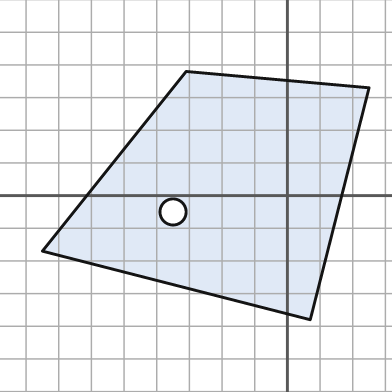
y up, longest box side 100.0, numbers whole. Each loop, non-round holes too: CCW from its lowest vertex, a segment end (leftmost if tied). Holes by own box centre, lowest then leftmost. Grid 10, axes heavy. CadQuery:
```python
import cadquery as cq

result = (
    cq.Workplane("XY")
    .moveTo(7.0, -38.0)
    .lineTo(25.0, 33.0)
    .lineTo(-31.0, 38.0)
    .lineTo(-75.0, -17.0)
    .close()
    .moveTo(-35.0, -5.0)
    .circle(4.0)
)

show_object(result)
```